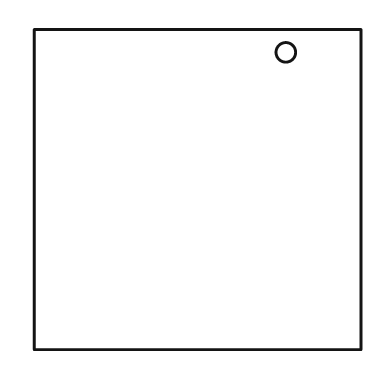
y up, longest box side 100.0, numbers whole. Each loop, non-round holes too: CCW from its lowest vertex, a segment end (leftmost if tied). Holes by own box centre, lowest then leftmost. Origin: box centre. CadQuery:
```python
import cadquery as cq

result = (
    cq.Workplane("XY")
    .moveTo(-50.0, -49.0)
    .lineTo(50.0, -49.0)
    .lineTo(50.0, 49.0)
    .lineTo(-50.0, 49.0)
    .close()
    .moveTo(27.0, 42.0)
    .circle(3.0)
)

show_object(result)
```